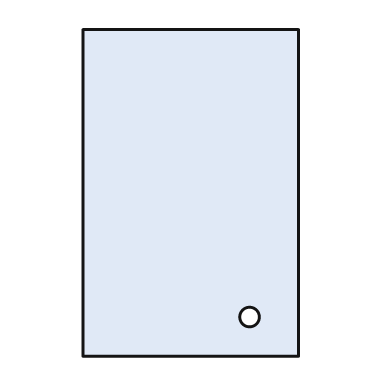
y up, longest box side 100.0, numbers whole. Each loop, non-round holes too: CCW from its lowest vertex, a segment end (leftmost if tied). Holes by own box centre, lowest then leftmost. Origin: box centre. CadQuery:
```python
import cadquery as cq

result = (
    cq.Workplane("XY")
    .moveTo(-33.0, -50.0)
    .lineTo(33.0, -50.0)
    .lineTo(33.0, 50.0)
    .lineTo(-33.0, 50.0)
    .close()
    .moveTo(18.0, -38.0)
    .circle(3.0)
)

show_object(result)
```